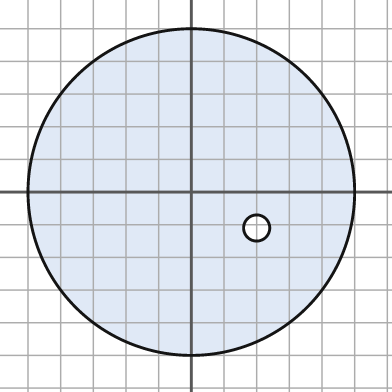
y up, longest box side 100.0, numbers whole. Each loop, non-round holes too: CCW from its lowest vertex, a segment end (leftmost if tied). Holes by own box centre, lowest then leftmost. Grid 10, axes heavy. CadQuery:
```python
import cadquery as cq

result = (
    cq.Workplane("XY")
    .moveTo(0.0, 0.0)
    .circle(50.0)
    .moveTo(20.0, -11.0)
    .circle(4.0)
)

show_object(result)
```